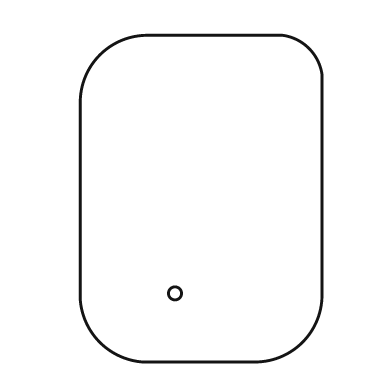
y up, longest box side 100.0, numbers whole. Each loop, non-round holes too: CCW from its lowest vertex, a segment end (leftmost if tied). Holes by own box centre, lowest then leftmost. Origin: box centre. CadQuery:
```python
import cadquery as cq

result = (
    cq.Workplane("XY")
    .moveTo(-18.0, -50.0)
    .lineTo(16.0, -50.0)
    .threePointArc((31.0, -44.0), (37.0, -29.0))
    .lineTo(37.0, 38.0)
    .threePointArc((33.0, 46.0), (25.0, 50.0))
    .lineTo(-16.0, 50.0)
    .threePointArc((-31.0, 44.0), (-37.0, 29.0))
    .lineTo(-37.0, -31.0)
    .threePointArc((-31.0, -44.0), (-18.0, -50.0))
    .close()
    .moveTo(-8.0, -29.0)
    .circle(2.0)
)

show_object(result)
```